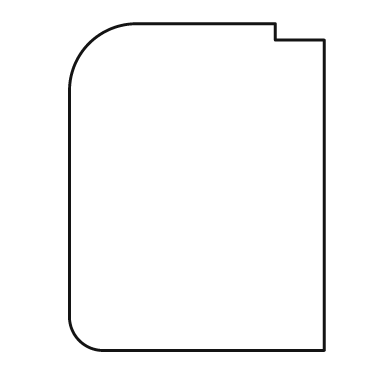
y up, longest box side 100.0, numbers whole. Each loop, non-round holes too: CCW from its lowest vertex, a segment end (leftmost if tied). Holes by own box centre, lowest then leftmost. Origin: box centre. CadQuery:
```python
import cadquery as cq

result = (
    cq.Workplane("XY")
    .moveTo(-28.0, -50.0)
    .lineTo(39.0, -50.0)
    .lineTo(39.0, 45.0)
    .lineTo(24.0, 45.0)
    .lineTo(24.0, 50.0)
    .lineTo(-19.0, 50.0)
    .threePointArc((-33.0, 44.0), (-39.0, 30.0))
    .lineTo(-39.0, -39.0)
    .threePointArc((-36.0, -47.0), (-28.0, -50.0))
    .close()
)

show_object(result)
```